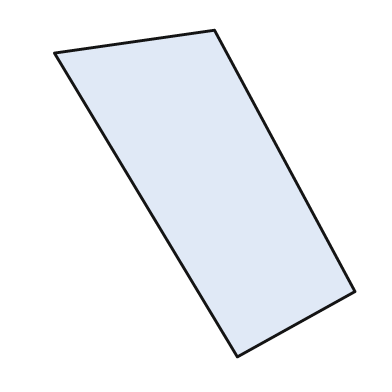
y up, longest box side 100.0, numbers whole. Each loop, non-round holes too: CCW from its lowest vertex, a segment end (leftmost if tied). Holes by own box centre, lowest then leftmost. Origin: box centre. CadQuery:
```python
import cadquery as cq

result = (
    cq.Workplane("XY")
    .moveTo(10.0, -50.0)
    .lineTo(46.0, -30.0)
    .lineTo(3.0, 50.0)
    .lineTo(-46.0, 43.0)
    .close()
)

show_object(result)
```